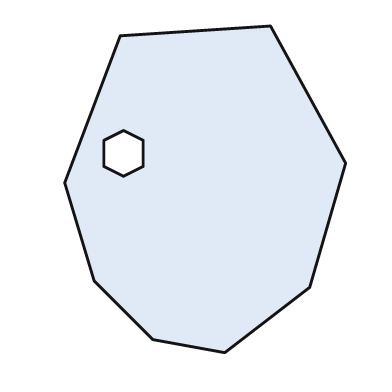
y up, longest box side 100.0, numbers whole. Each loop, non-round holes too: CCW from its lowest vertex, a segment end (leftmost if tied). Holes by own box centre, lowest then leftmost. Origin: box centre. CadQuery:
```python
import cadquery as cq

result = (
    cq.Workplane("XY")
    .moveTo(6.0, -50.0)
    .lineTo(32.0, -30.0)
    .lineTo(43.0, 8.0)
    .lineTo(20.0, 50.0)
    .lineTo(-26.0, 47.0)
    .lineTo(-43.0, 2.0)
    .lineTo(-34.0, -28.0)
    .lineTo(-16.0, -46.0)
    .close()
    .moveTo(-25.0, 4.0)
    .lineTo(-19.0, 7.0)
    .lineTo(-19.0, 15.0)
    .lineTo(-25.0, 18.0)
    .lineTo(-31.0, 15.0)
    .lineTo(-31.0, 7.0)
    .close()
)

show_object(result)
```